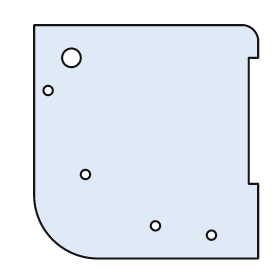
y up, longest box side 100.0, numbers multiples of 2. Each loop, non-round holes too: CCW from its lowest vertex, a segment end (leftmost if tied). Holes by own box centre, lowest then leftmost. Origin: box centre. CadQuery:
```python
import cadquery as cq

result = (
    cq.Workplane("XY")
    .moveTo(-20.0, -50.0)
    .lineTo(48.0, -50.0)
    .lineTo(48.0, -18.0)
    .lineTo(44.0, -18.0)
    .lineTo(44.0, 36.0)
    .lineTo(48.0, 36.0)
    .lineTo(48.0, 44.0)
    .threePointArc((46.0, 48.0), (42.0, 50.0))
    .lineTo(-48.0, 50.0)
    .lineTo(-48.0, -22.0)
    .threePointArc((-40.0, -42.0), (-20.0, -50.0))
    .close()
    .moveTo(28.0, -40.0)
    .circle(2.0)
    .moveTo(4.0, -36.0)
    .circle(2.0)
    .moveTo(-26.0, -14.0)
    .circle(2.0)
    .moveTo(-42.0, 22.0)
    .circle(2.0)
    .moveTo(-32.0, 36.0)
    .circle(4.0)
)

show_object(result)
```